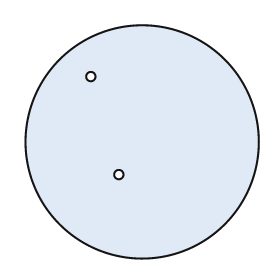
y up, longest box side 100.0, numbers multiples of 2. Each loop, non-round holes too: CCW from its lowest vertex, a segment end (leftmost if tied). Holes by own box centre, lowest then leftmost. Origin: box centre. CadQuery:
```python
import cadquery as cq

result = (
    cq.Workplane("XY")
    .moveTo(0.0, 0.0)
    .circle(50.0)
    .moveTo(-10.0, -14.0)
    .circle(2.0)
    .moveTo(-22.0, 28.0)
    .circle(2.0)
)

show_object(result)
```